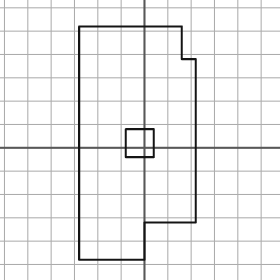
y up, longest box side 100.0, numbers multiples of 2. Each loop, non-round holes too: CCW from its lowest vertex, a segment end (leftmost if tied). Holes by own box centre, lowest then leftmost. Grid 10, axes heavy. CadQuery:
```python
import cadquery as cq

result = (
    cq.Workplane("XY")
    .moveTo(-28.0, -48.0)
    .lineTo(0.0, -48.0)
    .lineTo(0.0, -32.0)
    .lineTo(22.0, -32.0)
    .lineTo(22.0, 38.0)
    .lineTo(16.0, 38.0)
    .lineTo(16.0, 52.0)
    .lineTo(-28.0, 52.0)
    .close()
    .moveTo(-8.0, -4.0)
    .lineTo(4.0, -4.0)
    .lineTo(4.0, 8.0)
    .lineTo(-8.0, 8.0)
    .close()
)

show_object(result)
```